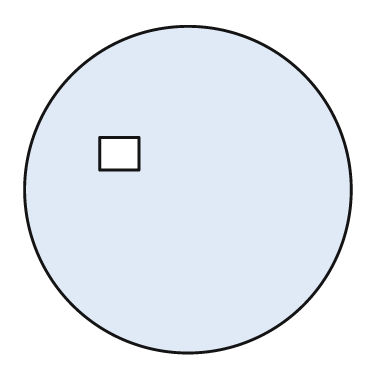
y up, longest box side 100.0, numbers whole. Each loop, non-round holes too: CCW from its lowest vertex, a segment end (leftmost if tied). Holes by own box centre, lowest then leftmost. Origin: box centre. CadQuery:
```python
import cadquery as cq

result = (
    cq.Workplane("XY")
    .moveTo(0.0, 0.0)
    .circle(50.0)
    .moveTo(-27.0, 6.0)
    .lineTo(-15.0, 6.0)
    .lineTo(-15.0, 16.0)
    .lineTo(-27.0, 16.0)
    .close()
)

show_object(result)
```